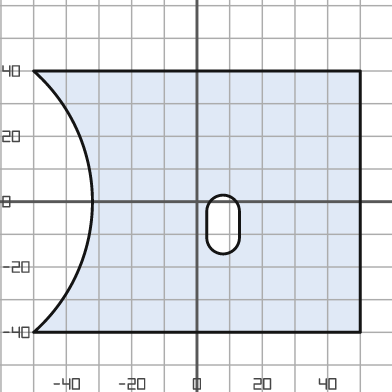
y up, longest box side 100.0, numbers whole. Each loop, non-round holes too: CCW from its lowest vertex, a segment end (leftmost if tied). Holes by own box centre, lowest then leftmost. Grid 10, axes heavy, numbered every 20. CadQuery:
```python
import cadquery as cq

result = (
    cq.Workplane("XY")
    .moveTo(-50.0, -40.0)
    .lineTo(50.0, -40.0)
    .lineTo(50.0, 40.0)
    .lineTo(-50.0, 40.0)
    .threePointArc((-32.0, 0.0), (-50.0, -40.0))
    .close()
    .moveTo(3.0, -11.0)
    .threePointArc((8.0, -16.0), (13.0, -11.0))
    .lineTo(13.0, -3.0)
    .threePointArc((8.0, 2.0), (3.0, -3.0))
    .close()
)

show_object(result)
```